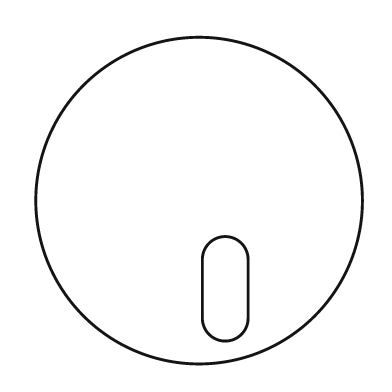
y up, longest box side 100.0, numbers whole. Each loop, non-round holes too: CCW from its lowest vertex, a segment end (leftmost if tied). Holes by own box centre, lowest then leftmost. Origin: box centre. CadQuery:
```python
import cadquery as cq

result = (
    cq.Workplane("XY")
    .moveTo(0.0, 0.0)
    .circle(50.0)
    .moveTo(1.0, -36.0)
    .threePointArc((8.0, -43.0), (15.0, -36.0))
    .lineTo(15.0, -18.0)
    .threePointArc((8.0, -11.0), (1.0, -18.0))
    .close()
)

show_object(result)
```